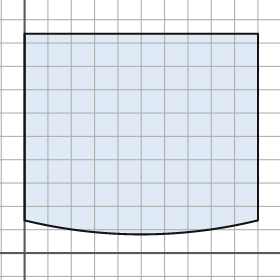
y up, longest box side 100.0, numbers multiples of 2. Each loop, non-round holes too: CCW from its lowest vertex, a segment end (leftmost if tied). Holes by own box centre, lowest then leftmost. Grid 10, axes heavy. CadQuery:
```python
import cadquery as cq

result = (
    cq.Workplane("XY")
    .moveTo(0.0, 14.0)
    .threePointArc((50.0, 8.0), (100.0, 14.0))
    .lineTo(100.0, 94.0)
    .lineTo(0.0, 94.0)
    .close()
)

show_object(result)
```